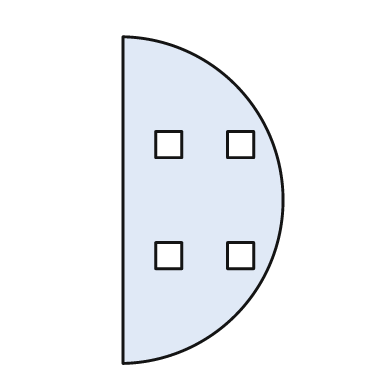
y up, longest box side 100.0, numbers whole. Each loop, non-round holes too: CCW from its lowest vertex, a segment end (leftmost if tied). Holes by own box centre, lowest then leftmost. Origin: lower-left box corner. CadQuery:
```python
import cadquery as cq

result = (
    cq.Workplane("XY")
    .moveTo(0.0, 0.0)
    .threePointArc((49.0, 50.0), (0.0, 100.0))
    .close()
    .moveTo(10.0, 29.0)
    .lineTo(18.0, 29.0)
    .lineTo(18.0, 37.0)
    .lineTo(10.0, 37.0)
    .close()
    .moveTo(32.0, 29.0)
    .lineTo(40.0, 29.0)
    .lineTo(40.0, 37.0)
    .lineTo(32.0, 37.0)
    .close()
    .moveTo(10.0, 63.0)
    .lineTo(18.0, 63.0)
    .lineTo(18.0, 71.0)
    .lineTo(10.0, 71.0)
    .close()
    .moveTo(32.0, 63.0)
    .lineTo(40.0, 63.0)
    .lineTo(40.0, 71.0)
    .lineTo(32.0, 71.0)
    .close()
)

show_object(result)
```